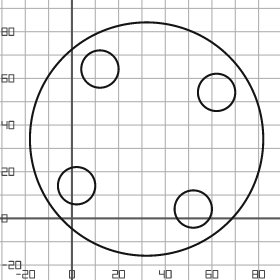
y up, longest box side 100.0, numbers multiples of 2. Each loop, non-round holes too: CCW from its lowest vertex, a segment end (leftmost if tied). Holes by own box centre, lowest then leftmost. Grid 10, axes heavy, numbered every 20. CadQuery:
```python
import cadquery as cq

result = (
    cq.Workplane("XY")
    .moveTo(32.0, 34.0)
    .circle(50.0)
    .moveTo(52.0, 4.0)
    .circle(8.0)
    .moveTo(2.0, 14.0)
    .circle(8.0)
    .moveTo(62.0, 54.0)
    .circle(8.0)
    .moveTo(12.0, 64.0)
    .circle(8.0)
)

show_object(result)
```